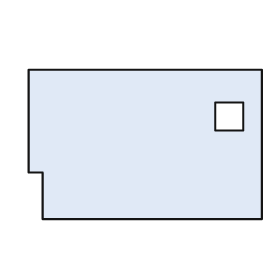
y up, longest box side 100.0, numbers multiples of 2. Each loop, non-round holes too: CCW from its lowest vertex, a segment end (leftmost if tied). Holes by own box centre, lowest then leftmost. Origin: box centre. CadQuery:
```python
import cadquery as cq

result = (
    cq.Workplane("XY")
    .moveTo(-44.0, -32.0)
    .lineTo(50.0, -32.0)
    .lineTo(50.0, 32.0)
    .lineTo(-50.0, 32.0)
    .lineTo(-50.0, -12.0)
    .lineTo(-44.0, -12.0)
    .close()
    .moveTo(30.0, 6.0)
    .lineTo(42.0, 6.0)
    .lineTo(42.0, 18.0)
    .lineTo(30.0, 18.0)
    .close()
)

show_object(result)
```